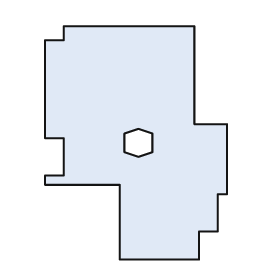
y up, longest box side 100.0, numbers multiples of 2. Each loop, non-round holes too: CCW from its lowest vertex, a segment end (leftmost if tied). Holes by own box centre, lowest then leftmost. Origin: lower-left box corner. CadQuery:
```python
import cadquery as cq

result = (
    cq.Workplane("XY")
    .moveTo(32.0, 0.0)
    .lineTo(66.0, 0.0)
    .lineTo(66.0, 12.0)
    .lineTo(74.0, 12.0)
    .lineTo(74.0, 28.0)
    .lineTo(78.0, 28.0)
    .lineTo(78.0, 58.0)
    .lineTo(64.0, 58.0)
    .lineTo(64.0, 100.0)
    .lineTo(8.0, 100.0)
    .lineTo(8.0, 94.0)
    .lineTo(0.0, 94.0)
    .lineTo(0.0, 52.0)
    .lineTo(8.0, 52.0)
    .lineTo(8.0, 36.0)
    .lineTo(0.0, 36.0)
    .lineTo(0.0, 32.0)
    .lineTo(32.0, 32.0)
    .close()
    .moveTo(40.0, 44.0)
    .lineTo(46.0, 46.0)
    .lineTo(46.0, 54.0)
    .lineTo(40.0, 56.0)
    .lineTo(34.0, 54.0)
    .lineTo(34.0, 46.0)
    .close()
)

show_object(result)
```